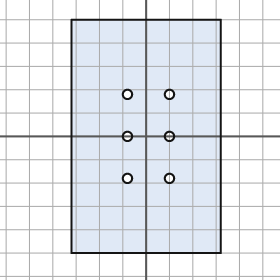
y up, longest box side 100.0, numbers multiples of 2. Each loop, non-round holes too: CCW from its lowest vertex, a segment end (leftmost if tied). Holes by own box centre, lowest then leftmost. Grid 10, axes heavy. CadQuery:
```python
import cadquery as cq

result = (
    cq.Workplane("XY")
    .moveTo(-32.0, -50.0)
    .lineTo(32.0, -50.0)
    .lineTo(32.0, 50.0)
    .lineTo(-32.0, 50.0)
    .close()
    .moveTo(-8.0, -18.0)
    .circle(2.0)
    .moveTo(10.0, -18.0)
    .circle(2.0)
    .moveTo(-8.0, 0.0)
    .circle(2.0)
    .moveTo(10.0, 0.0)
    .circle(2.0)
    .moveTo(-8.0, 18.0)
    .circle(2.0)
    .moveTo(10.0, 18.0)
    .circle(2.0)
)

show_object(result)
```